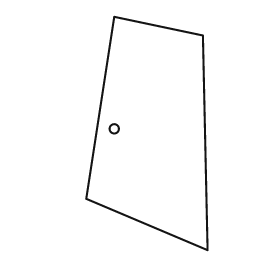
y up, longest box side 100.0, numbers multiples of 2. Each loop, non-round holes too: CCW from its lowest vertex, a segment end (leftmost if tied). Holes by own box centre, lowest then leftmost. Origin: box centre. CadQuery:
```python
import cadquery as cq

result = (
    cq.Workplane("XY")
    .moveTo(26.0, -50.0)
    .lineTo(24.0, 42.0)
    .lineTo(-14.0, 50.0)
    .lineTo(-26.0, -28.0)
    .close()
    .moveTo(-14.0, 2.0)
    .circle(2.0)
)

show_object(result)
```